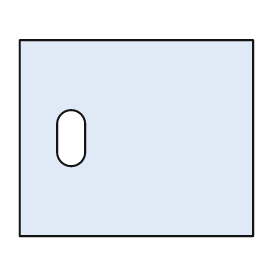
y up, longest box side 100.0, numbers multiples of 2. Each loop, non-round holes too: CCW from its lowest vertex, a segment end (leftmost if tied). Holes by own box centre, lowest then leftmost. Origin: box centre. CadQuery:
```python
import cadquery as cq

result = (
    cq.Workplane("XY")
    .moveTo(-50.0, -42.0)
    .lineTo(50.0, -42.0)
    .lineTo(50.0, 42.0)
    .lineTo(-50.0, 42.0)
    .close()
    .moveTo(-34.0, -6.0)
    .threePointArc((-28.0, -12.0), (-22.0, -6.0))
    .lineTo(-22.0, 6.0)
    .threePointArc((-28.0, 12.0), (-34.0, 6.0))
    .close()
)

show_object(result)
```